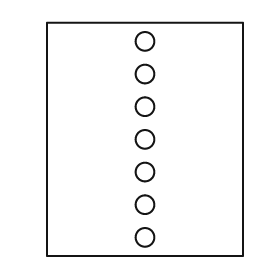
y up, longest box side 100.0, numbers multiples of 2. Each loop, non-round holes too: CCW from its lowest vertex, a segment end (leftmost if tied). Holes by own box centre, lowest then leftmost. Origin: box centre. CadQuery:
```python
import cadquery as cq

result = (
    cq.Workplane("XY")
    .moveTo(-42.0, -50.0)
    .lineTo(42.0, -50.0)
    .lineTo(42.0, 50.0)
    .lineTo(-42.0, 50.0)
    .close()
    .moveTo(0.0, -42.0)
    .circle(4.0)
    .moveTo(0.0, -28.0)
    .circle(4.0)
    .moveTo(0.0, -14.0)
    .circle(4.0)
    .moveTo(0.0, 0.0)
    .circle(4.0)
    .moveTo(0.0, 14.0)
    .circle(4.0)
    .moveTo(0.0, 28.0)
    .circle(4.0)
    .moveTo(0.0, 42.0)
    .circle(4.0)
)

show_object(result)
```